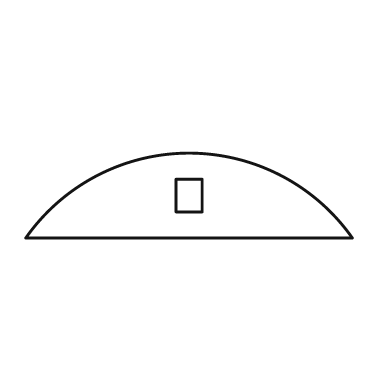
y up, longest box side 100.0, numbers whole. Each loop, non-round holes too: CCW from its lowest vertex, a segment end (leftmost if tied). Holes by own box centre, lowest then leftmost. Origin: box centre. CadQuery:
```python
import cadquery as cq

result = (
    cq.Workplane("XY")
    .moveTo(-50.0, -13.0)
    .lineTo(50.0, -13.0)
    .threePointArc((0.0, 13.0), (-50.0, -13.0))
    .close()
    .moveTo(-4.0, -5.0)
    .lineTo(4.0, -5.0)
    .lineTo(4.0, 5.0)
    .lineTo(-4.0, 5.0)
    .close()
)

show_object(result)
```